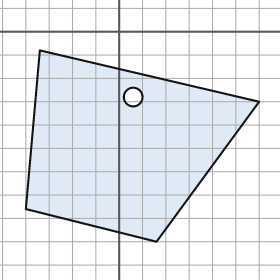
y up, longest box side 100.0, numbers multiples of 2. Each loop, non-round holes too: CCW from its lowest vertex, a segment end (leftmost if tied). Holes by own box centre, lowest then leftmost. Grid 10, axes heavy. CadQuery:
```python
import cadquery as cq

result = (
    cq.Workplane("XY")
    .moveTo(16.0, -90.0)
    .lineTo(60.0, -30.0)
    .lineTo(-34.0, -8.0)
    .lineTo(-40.0, -76.0)
    .close()
    .moveTo(6.0, -28.0)
    .circle(4.0)
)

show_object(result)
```